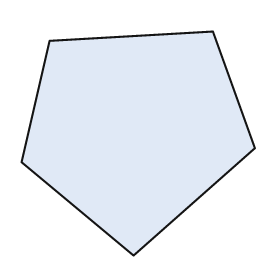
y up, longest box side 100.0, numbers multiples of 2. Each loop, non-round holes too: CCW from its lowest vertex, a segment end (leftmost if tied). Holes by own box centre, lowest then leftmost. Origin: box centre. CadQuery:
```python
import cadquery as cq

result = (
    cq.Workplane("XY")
    .moveTo(-2.0, -48.0)
    .lineTo(50.0, -2.0)
    .lineTo(32.0, 48.0)
    .lineTo(-38.0, 44.0)
    .lineTo(-50.0, -8.0)
    .close()
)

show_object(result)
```